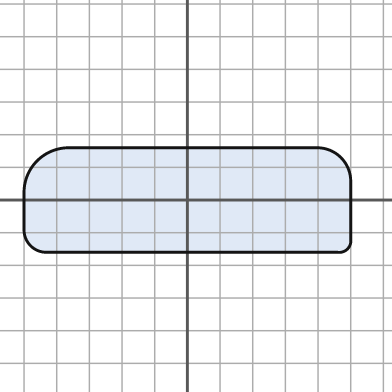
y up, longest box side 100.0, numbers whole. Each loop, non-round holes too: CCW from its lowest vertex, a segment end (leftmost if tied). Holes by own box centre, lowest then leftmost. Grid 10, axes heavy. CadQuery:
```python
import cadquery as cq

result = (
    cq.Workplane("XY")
    .moveTo(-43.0, -16.0)
    .lineTo(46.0, -16.0)
    .threePointArc((49.0, -15.0), (50.0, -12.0))
    .lineTo(50.0, 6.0)
    .threePointArc((47.0, 13.0), (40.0, 16.0))
    .lineTo(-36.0, 16.0)
    .threePointArc((-46.0, 12.0), (-50.0, 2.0))
    .lineTo(-50.0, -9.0)
    .threePointArc((-48.0, -14.0), (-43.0, -16.0))
    .close()
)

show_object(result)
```